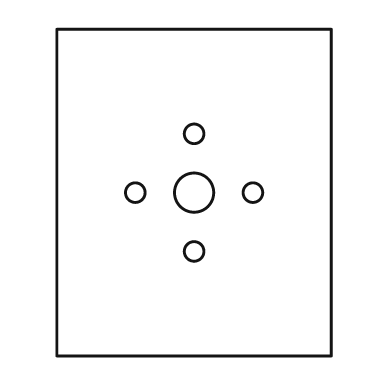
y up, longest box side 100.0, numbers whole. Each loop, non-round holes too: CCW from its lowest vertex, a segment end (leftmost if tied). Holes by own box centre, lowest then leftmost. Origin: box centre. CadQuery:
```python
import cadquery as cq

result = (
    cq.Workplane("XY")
    .moveTo(-42.0, -50.0)
    .lineTo(42.0, -50.0)
    .lineTo(42.0, 50.0)
    .lineTo(-42.0, 50.0)
    .close()
    .moveTo(0.0, -18.0)
    .circle(3.0)
    .moveTo(-18.0, 0.0)
    .circle(3.0)
    .moveTo(0.0, 0.0)
    .circle(6.0)
    .moveTo(18.0, 0.0)
    .circle(3.0)
    .moveTo(0.0, 18.0)
    .circle(3.0)
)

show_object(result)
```